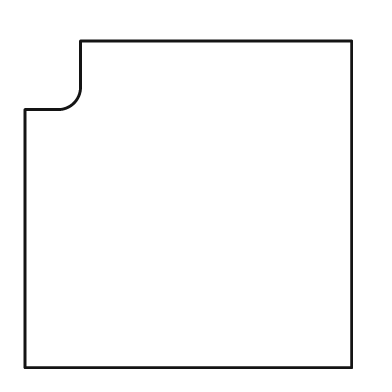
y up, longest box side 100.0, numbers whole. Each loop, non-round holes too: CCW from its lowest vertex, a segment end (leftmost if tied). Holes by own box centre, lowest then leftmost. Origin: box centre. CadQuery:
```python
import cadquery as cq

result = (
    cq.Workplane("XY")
    .moveTo(-50.0, -50.0)
    .lineTo(50.0, -50.0)
    .lineTo(50.0, 50.0)
    .lineTo(-33.0, 50.0)
    .lineTo(-33.0, 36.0)
    .threePointArc((-35.0, 31.0), (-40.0, 29.0))
    .lineTo(-50.0, 29.0)
    .close()
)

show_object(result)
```